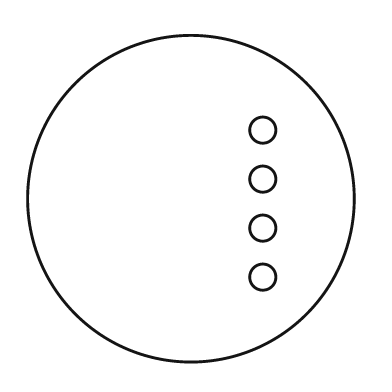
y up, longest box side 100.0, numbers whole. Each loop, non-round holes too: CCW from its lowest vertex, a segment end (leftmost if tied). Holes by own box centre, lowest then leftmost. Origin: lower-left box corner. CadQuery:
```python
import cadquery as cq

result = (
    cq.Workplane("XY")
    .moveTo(50.0, 50.0)
    .circle(50.0)
    .moveTo(72.0, 26.0)
    .circle(4.0)
    .moveTo(72.0, 41.0)
    .circle(4.0)
    .moveTo(72.0, 56.0)
    .circle(4.0)
    .moveTo(72.0, 71.0)
    .circle(4.0)
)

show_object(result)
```